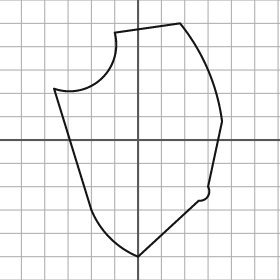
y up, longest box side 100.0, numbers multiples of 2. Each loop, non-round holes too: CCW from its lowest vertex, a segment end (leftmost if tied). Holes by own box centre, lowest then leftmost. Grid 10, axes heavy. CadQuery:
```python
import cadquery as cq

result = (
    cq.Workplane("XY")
    .moveTo(0.0, -50.0)
    .lineTo(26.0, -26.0)
    .threePointArc((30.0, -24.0), (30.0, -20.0))
    .lineTo(36.0, 8.0)
    .threePointArc((30.0, 30.0), (18.0, 50.0))
    .lineTo(-10.0, 46.0)
    .threePointArc((-16.0, 26.0), (-36.0, 22.0))
    .lineTo(-20.0, -30.0)
    .threePointArc((-12.0, -42.0), (0.0, -50.0))
    .close()
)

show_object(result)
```